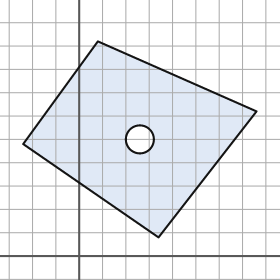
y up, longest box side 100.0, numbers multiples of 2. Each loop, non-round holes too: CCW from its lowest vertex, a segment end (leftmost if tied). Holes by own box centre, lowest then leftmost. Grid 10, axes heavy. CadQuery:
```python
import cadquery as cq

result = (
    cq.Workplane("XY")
    .moveTo(34.0, 8.0)
    .lineTo(76.0, 62.0)
    .lineTo(8.0, 92.0)
    .lineTo(-24.0, 48.0)
    .close()
    .moveTo(26.0, 50.0)
    .circle(6.0)
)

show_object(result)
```